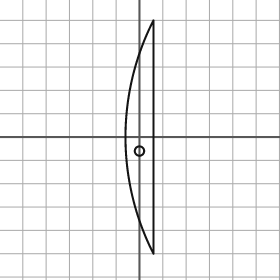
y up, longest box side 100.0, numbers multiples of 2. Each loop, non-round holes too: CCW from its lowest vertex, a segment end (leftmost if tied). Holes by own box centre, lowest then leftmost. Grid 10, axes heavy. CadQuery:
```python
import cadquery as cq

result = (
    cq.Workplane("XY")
    .moveTo(6.0, -50.0)
    .lineTo(6.0, 50.0)
    .threePointArc((-6.0, 0.0), (6.0, -50.0))
    .close()
    .moveTo(0.0, -6.0)
    .circle(2.0)
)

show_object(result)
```